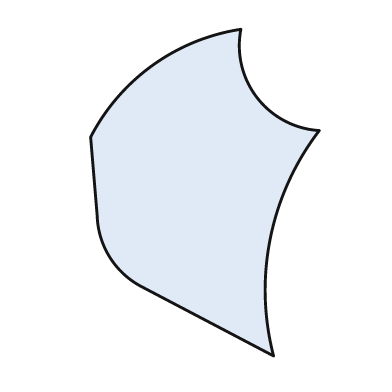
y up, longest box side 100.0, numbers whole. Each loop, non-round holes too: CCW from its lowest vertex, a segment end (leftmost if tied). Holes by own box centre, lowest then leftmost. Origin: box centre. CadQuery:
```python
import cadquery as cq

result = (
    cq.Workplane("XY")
    .moveTo(21.0, -50.0)
    .threePointArc((20.0, -14.0), (35.0, 19.0))
    .threePointArc((16.0, 29.0), (11.0, 50.0))
    .threePointArc((-16.0, 39.0), (-35.0, 17.0))
    .lineTo(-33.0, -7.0)
    .threePointArc((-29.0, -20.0), (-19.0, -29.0))
    .close()
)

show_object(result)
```